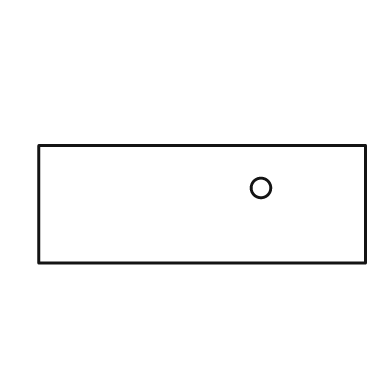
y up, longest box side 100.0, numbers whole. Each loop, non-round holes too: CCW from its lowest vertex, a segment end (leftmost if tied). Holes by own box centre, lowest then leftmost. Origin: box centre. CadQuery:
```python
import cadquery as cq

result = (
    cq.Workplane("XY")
    .moveTo(-50.0, -18.0)
    .lineTo(50.0, -18.0)
    .lineTo(50.0, 18.0)
    .lineTo(-50.0, 18.0)
    .close()
    .moveTo(18.0, 5.0)
    .circle(3.0)
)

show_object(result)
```